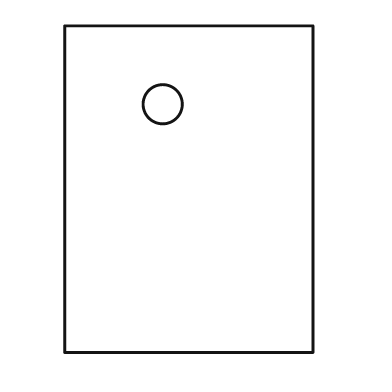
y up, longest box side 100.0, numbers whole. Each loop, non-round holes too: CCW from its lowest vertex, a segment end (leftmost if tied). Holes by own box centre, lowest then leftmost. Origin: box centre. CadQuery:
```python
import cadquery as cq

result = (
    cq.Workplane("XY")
    .moveTo(-38.0, -50.0)
    .lineTo(38.0, -50.0)
    .lineTo(38.0, 50.0)
    .lineTo(-38.0, 50.0)
    .close()
    .moveTo(-8.0, 26.0)
    .circle(6.0)
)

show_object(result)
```